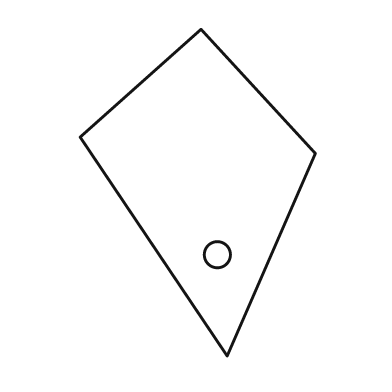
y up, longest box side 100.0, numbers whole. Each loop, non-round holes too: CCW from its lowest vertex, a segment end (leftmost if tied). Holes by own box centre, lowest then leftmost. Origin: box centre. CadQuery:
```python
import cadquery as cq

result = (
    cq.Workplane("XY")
    .moveTo(9.0, -50.0)
    .lineTo(36.0, 12.0)
    .lineTo(1.0, 50.0)
    .lineTo(-36.0, 17.0)
    .close()
    .moveTo(6.0, -19.0)
    .circle(4.0)
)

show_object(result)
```